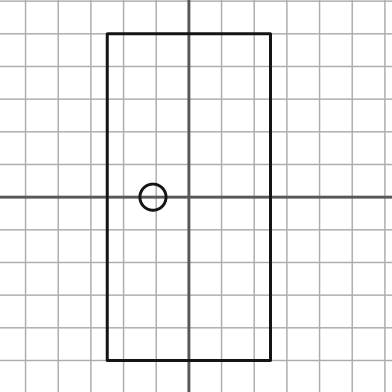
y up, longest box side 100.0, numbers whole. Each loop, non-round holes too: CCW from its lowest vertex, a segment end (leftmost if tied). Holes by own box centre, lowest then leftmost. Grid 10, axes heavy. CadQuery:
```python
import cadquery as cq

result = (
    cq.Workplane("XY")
    .moveTo(-25.0, -50.0)
    .lineTo(25.0, -50.0)
    .lineTo(25.0, 50.0)
    .lineTo(-25.0, 50.0)
    .close()
    .moveTo(-11.0, 0.0)
    .circle(4.0)
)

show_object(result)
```